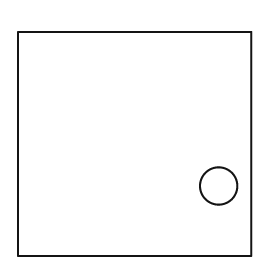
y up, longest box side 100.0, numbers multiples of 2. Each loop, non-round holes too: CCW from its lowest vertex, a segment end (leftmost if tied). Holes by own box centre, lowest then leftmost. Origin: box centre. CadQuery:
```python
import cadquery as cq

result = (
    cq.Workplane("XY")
    .moveTo(-50.0, -48.0)
    .lineTo(50.0, -48.0)
    .lineTo(50.0, 48.0)
    .lineTo(-50.0, 48.0)
    .close()
    .moveTo(36.0, -18.0)
    .circle(8.0)
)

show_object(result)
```